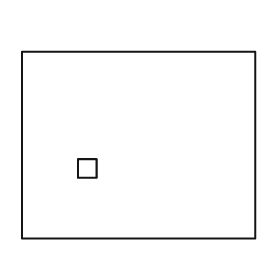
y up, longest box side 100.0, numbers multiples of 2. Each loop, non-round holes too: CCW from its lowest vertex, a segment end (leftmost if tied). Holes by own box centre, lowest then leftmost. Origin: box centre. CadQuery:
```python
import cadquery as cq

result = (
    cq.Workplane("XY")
    .moveTo(-50.0, -40.0)
    .lineTo(50.0, -40.0)
    .lineTo(50.0, 40.0)
    .lineTo(-50.0, 40.0)
    .close()
    .moveTo(-26.0, -14.0)
    .lineTo(-18.0, -14.0)
    .lineTo(-18.0, -6.0)
    .lineTo(-26.0, -6.0)
    .close()
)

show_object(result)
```